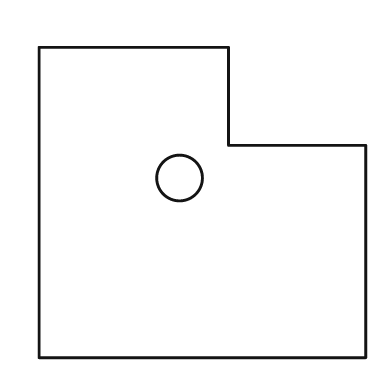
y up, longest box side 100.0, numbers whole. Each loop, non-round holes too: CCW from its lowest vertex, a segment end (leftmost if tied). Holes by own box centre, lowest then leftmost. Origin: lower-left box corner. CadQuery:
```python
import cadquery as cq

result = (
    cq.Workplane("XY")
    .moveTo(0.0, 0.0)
    .lineTo(100.0, 0.0)
    .lineTo(100.0, 65.0)
    .lineTo(58.0, 65.0)
    .lineTo(58.0, 95.0)
    .lineTo(0.0, 95.0)
    .close()
    .moveTo(43.0, 55.0)
    .circle(7.0)
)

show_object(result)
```